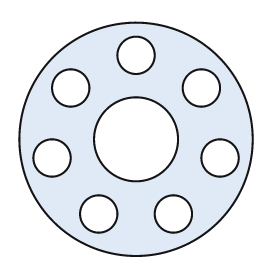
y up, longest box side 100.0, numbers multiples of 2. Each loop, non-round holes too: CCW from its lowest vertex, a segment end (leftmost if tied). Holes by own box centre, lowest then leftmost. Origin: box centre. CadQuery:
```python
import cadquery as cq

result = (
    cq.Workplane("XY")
    .moveTo(0.0, 0.0)
    .circle(50.0)
    .moveTo(-16.0, -32.0)
    .circle(8.0)
    .moveTo(16.0, -32.0)
    .circle(8.0)
    .moveTo(-36.0, -8.0)
    .circle(8.0)
    .moveTo(36.0, -8.0)
    .circle(8.0)
    .moveTo(0.0, 0.0)
    .circle(18.0)
    .moveTo(-28.0, 22.0)
    .circle(8.0)
    .moveTo(28.0, 22.0)
    .circle(8.0)
    .moveTo(0.0, 36.0)
    .circle(8.0)
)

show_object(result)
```